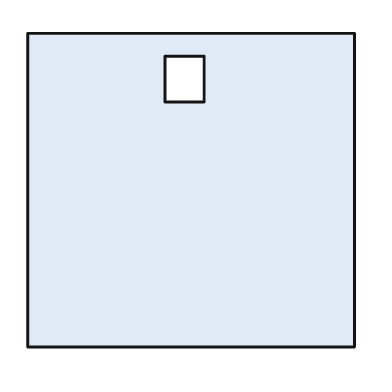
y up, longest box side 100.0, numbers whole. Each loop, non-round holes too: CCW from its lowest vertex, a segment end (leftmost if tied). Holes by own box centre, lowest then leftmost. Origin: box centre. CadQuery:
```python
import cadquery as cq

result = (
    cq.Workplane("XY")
    .moveTo(-50.0, -48.0)
    .lineTo(50.0, -48.0)
    .lineTo(50.0, 48.0)
    .lineTo(-50.0, 48.0)
    .close()
    .moveTo(-8.0, 27.0)
    .lineTo(4.0, 27.0)
    .lineTo(4.0, 41.0)
    .lineTo(-8.0, 41.0)
    .close()
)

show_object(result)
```